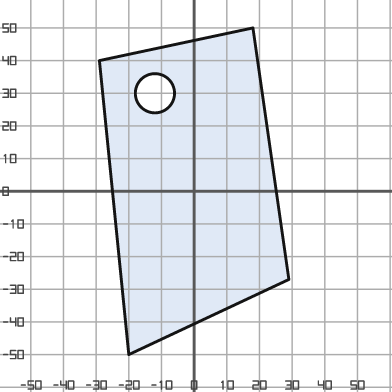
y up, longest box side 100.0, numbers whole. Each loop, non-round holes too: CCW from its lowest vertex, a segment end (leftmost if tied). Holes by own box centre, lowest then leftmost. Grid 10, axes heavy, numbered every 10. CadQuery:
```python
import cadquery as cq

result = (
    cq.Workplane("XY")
    .moveTo(-20.0, -50.0)
    .lineTo(29.0, -27.0)
    .lineTo(18.0, 50.0)
    .lineTo(-29.0, 40.0)
    .close()
    .moveTo(-12.0, 30.0)
    .circle(6.0)
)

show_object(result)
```